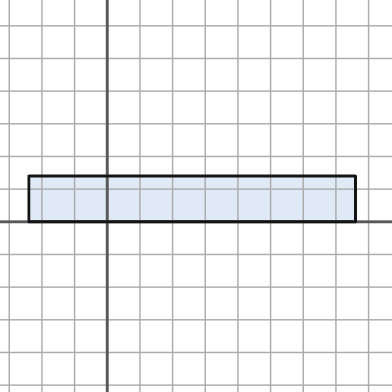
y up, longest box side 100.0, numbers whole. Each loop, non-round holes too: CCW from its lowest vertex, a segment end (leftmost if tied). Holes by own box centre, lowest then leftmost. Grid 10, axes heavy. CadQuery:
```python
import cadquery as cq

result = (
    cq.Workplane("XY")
    .moveTo(-24.0, 0.0)
    .lineTo(76.0, 0.0)
    .lineTo(76.0, 14.0)
    .lineTo(-24.0, 14.0)
    .close()
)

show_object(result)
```